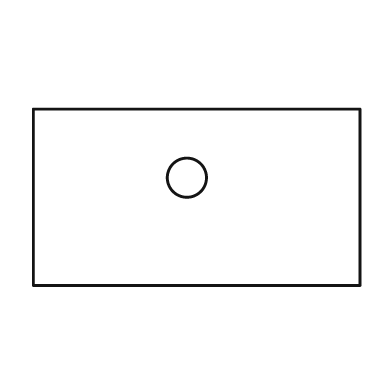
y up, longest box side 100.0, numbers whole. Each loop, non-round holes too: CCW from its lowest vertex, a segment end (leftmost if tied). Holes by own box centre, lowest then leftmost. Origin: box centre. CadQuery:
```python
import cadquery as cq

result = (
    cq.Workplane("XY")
    .moveTo(-50.0, -27.0)
    .lineTo(50.0, -27.0)
    .lineTo(50.0, 27.0)
    .lineTo(-50.0, 27.0)
    .close()
    .moveTo(-3.0, 6.0)
    .circle(6.0)
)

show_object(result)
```